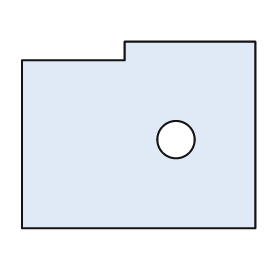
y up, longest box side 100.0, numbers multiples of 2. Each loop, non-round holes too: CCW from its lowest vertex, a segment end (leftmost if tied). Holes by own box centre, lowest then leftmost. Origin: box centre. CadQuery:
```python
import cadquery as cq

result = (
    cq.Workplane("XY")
    .moveTo(-50.0, -40.0)
    .lineTo(50.0, -40.0)
    .lineTo(50.0, 40.0)
    .lineTo(-6.0, 40.0)
    .lineTo(-6.0, 32.0)
    .lineTo(-50.0, 32.0)
    .close()
    .moveTo(16.0, -2.0)
    .circle(8.0)
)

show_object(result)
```